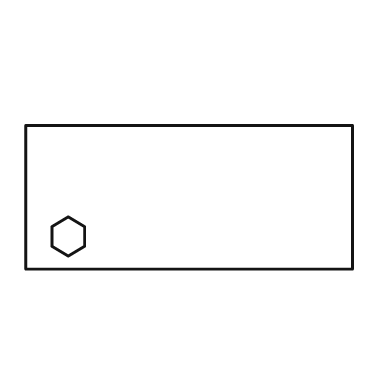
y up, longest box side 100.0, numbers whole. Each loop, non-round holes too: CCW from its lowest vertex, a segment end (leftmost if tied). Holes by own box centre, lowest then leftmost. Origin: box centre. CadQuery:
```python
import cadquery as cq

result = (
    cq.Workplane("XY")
    .moveTo(-50.0, -22.0)
    .lineTo(50.0, -22.0)
    .lineTo(50.0, 22.0)
    .lineTo(-50.0, 22.0)
    .close()
    .moveTo(-37.0, -18.0)
    .lineTo(-32.0, -15.0)
    .lineTo(-32.0, -9.0)
    .lineTo(-37.0, -6.0)
    .lineTo(-42.0, -9.0)
    .lineTo(-42.0, -15.0)
    .close()
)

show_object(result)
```